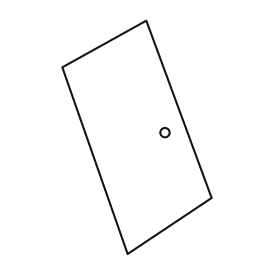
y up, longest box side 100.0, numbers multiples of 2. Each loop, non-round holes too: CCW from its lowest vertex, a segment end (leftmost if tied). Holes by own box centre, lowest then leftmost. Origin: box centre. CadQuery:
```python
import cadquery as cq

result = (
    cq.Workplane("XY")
    .moveTo(-4.0, -50.0)
    .lineTo(32.0, -26.0)
    .lineTo(4.0, 50.0)
    .lineTo(-32.0, 30.0)
    .close()
    .moveTo(12.0, 2.0)
    .circle(2.0)
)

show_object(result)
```